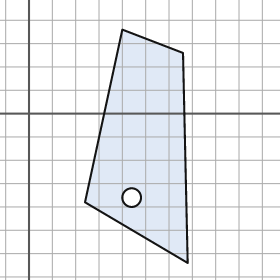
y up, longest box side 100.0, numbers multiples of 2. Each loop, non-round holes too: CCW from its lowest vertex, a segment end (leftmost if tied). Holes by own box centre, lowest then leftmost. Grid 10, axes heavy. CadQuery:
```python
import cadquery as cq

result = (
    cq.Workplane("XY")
    .moveTo(68.0, -64.0)
    .lineTo(66.0, 26.0)
    .lineTo(40.0, 36.0)
    .lineTo(24.0, -38.0)
    .close()
    .moveTo(44.0, -36.0)
    .circle(4.0)
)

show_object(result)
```